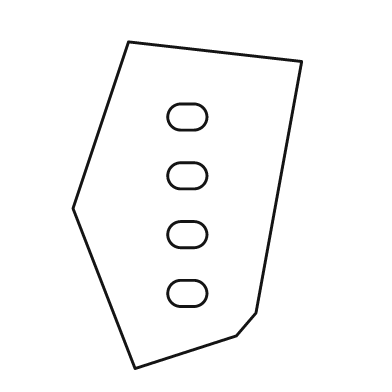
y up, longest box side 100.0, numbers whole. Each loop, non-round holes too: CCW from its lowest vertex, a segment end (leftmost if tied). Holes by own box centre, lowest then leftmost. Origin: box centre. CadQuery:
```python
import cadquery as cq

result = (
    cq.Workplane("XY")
    .moveTo(-16.0, -50.0)
    .lineTo(15.0, -40.0)
    .lineTo(21.0, -33.0)
    .lineTo(35.0, 44.0)
    .lineTo(-18.0, 50.0)
    .lineTo(-35.0, -1.0)
    .close()
    .moveTo(-2.0, -31.0)
    .lineTo(2.0, -31.0)
    .threePointArc((6.0, -27.0), (2.0, -23.0))
    .lineTo(-2.0, -23.0)
    .threePointArc((-6.0, -27.0), (-2.0, -31.0))
    .close()
    .moveTo(-2.0, -13.0)
    .lineTo(2.0, -13.0)
    .threePointArc((6.0, -9.0), (2.0, -5.0))
    .lineTo(-2.0, -5.0)
    .threePointArc((-6.0, -9.0), (-2.0, -13.0))
    .close()
    .moveTo(-2.0, 5.0)
    .lineTo(2.0, 5.0)
    .threePointArc((6.0, 9.0), (2.0, 13.0))
    .lineTo(-2.0, 13.0)
    .threePointArc((-6.0, 9.0), (-2.0, 5.0))
    .close()
    .moveTo(-2.0, 23.0)
    .lineTo(2.0, 23.0)
    .threePointArc((6.0, 27.0), (2.0, 31.0))
    .lineTo(-2.0, 31.0)
    .threePointArc((-6.0, 27.0), (-2.0, 23.0))
    .close()
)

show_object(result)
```